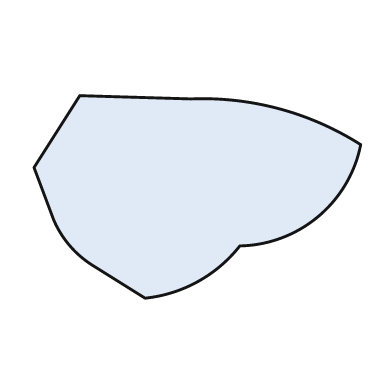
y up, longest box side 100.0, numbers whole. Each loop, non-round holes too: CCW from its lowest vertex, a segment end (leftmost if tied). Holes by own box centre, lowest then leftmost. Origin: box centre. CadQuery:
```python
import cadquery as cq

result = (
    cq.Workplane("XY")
    .moveTo(-16.0, -31.0)
    .threePointArc((0.0, -26.0), (13.0, -15.0))
    .threePointArc((37.0, -6.0), (50.0, 16.0))
    .threePointArc((25.0, 27.0), (-2.0, 30.0))
    .lineTo(-36.0, 31.0)
    .lineTo(-50.0, 9.0)
    .lineTo(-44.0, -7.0)
    .threePointArc((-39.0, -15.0), (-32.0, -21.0))
    .close()
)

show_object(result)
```